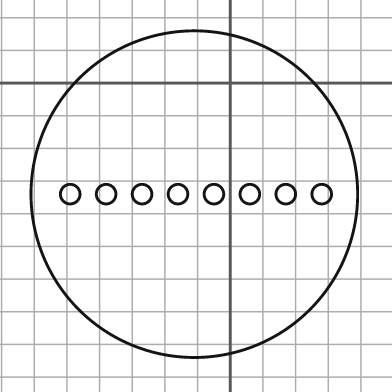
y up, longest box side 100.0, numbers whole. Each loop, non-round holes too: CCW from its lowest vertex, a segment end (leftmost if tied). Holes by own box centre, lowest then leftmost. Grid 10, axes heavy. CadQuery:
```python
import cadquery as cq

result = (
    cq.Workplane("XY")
    .moveTo(-11.0, -34.0)
    .circle(50.0)
    .moveTo(-49.0, -34.0)
    .circle(3.0)
    .moveTo(-38.0, -34.0)
    .circle(3.0)
    .moveTo(-27.0, -34.0)
    .circle(3.0)
    .moveTo(-16.0, -34.0)
    .circle(3.0)
    .moveTo(-5.0, -34.0)
    .circle(3.0)
    .moveTo(6.0, -34.0)
    .circle(3.0)
    .moveTo(17.0, -34.0)
    .circle(3.0)
    .moveTo(28.0, -34.0)
    .circle(3.0)
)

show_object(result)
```